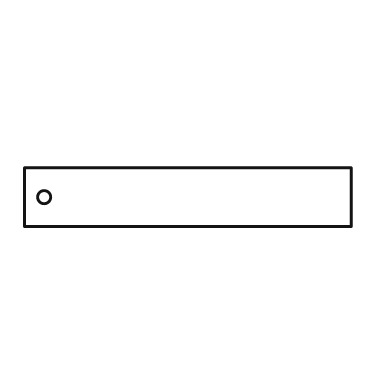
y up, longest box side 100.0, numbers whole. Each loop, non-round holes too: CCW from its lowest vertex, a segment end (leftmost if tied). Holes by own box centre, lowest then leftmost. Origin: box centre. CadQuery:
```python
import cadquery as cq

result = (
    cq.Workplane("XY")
    .moveTo(-50.0, -9.0)
    .lineTo(50.0, -9.0)
    .lineTo(50.0, 9.0)
    .lineTo(-50.0, 9.0)
    .close()
    .moveTo(-44.0, 0.0)
    .circle(2.0)
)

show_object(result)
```